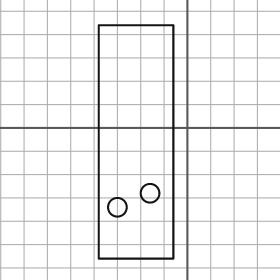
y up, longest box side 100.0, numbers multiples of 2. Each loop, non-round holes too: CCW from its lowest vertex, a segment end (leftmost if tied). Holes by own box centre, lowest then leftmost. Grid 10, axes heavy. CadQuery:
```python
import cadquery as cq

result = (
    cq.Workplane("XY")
    .moveTo(-38.0, -56.0)
    .lineTo(-6.0, -56.0)
    .lineTo(-6.0, 44.0)
    .lineTo(-38.0, 44.0)
    .close()
    .moveTo(-30.0, -34.0)
    .circle(4.0)
    .moveTo(-16.0, -28.0)
    .circle(4.0)
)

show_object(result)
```